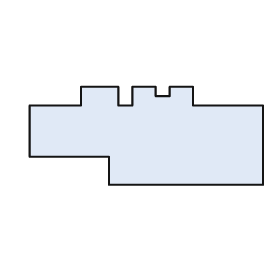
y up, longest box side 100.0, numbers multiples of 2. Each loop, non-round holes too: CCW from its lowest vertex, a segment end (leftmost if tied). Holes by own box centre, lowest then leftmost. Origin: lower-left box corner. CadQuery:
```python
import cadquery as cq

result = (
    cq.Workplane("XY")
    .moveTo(34.0, 0.0)
    .lineTo(100.0, 0.0)
    .lineTo(100.0, 34.0)
    .lineTo(70.0, 34.0)
    .lineTo(70.0, 42.0)
    .lineTo(60.0, 42.0)
    .lineTo(60.0, 38.0)
    .lineTo(54.0, 38.0)
    .lineTo(54.0, 42.0)
    .lineTo(44.0, 42.0)
    .lineTo(44.0, 34.0)
    .lineTo(38.0, 34.0)
    .lineTo(38.0, 42.0)
    .lineTo(22.0, 42.0)
    .lineTo(22.0, 34.0)
    .lineTo(0.0, 34.0)
    .lineTo(0.0, 12.0)
    .lineTo(34.0, 12.0)
    .close()
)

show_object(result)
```